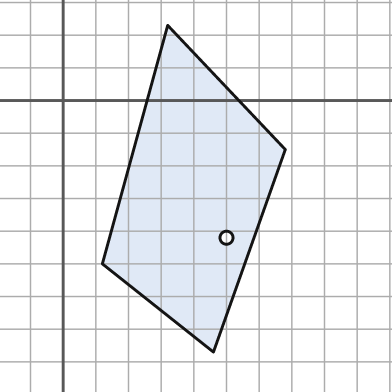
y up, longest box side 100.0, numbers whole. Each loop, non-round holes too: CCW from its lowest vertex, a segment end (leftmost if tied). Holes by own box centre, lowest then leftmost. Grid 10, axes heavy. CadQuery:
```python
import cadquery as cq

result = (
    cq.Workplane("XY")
    .moveTo(46.0, -77.0)
    .lineTo(68.0, -15.0)
    .lineTo(32.0, 23.0)
    .lineTo(12.0, -50.0)
    .close()
    .moveTo(50.0, -42.0)
    .circle(2.0)
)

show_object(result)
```